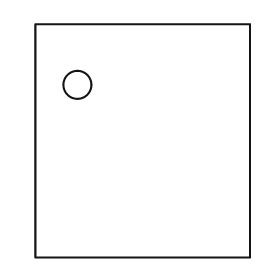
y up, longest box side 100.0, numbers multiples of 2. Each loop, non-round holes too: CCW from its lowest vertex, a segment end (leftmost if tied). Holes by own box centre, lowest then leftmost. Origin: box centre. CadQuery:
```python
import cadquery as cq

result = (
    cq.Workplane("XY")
    .moveTo(-46.0, -50.0)
    .lineTo(46.0, -50.0)
    .lineTo(46.0, 50.0)
    .lineTo(-46.0, 50.0)
    .close()
    .moveTo(-28.0, 24.0)
    .circle(6.0)
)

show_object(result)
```